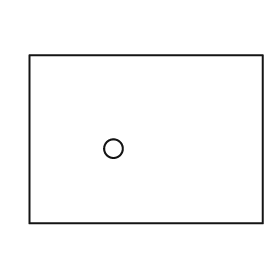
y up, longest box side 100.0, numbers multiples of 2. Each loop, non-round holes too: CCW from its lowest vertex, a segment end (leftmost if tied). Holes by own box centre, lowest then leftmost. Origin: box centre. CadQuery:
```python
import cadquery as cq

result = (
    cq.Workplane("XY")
    .moveTo(-50.0, -36.0)
    .lineTo(50.0, -36.0)
    .lineTo(50.0, 36.0)
    .lineTo(-50.0, 36.0)
    .close()
    .moveTo(-14.0, -4.0)
    .circle(4.0)
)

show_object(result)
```